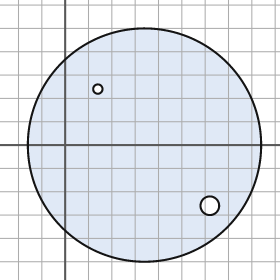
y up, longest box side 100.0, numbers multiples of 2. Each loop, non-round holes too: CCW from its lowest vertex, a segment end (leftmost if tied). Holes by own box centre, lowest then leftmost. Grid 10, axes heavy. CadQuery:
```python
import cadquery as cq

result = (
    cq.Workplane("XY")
    .moveTo(34.0, 0.0)
    .circle(50.0)
    .moveTo(62.0, -26.0)
    .circle(4.0)
    .moveTo(14.0, 24.0)
    .circle(2.0)
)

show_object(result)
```